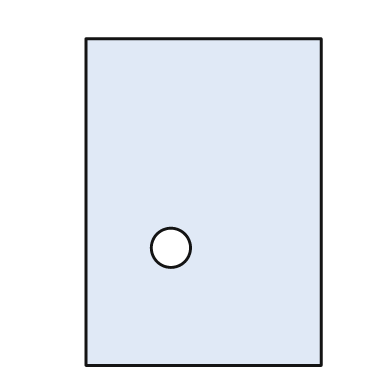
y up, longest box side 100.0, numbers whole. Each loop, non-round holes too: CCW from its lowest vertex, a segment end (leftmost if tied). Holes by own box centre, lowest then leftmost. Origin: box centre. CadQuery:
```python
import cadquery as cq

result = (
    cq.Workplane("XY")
    .moveTo(-36.0, -50.0)
    .lineTo(36.0, -50.0)
    .lineTo(36.0, 50.0)
    .lineTo(-36.0, 50.0)
    .close()
    .moveTo(-10.0, -14.0)
    .circle(6.0)
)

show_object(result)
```